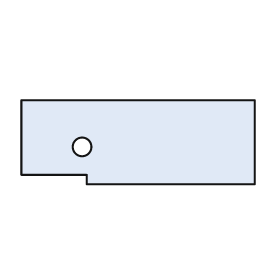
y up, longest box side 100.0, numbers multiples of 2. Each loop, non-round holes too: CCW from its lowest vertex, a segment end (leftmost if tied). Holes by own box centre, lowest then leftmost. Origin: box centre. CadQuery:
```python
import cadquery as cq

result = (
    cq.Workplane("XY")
    .moveTo(-22.0, -18.0)
    .lineTo(50.0, -18.0)
    .lineTo(50.0, 18.0)
    .lineTo(-50.0, 18.0)
    .lineTo(-50.0, -14.0)
    .lineTo(-22.0, -14.0)
    .close()
    .moveTo(-24.0, -2.0)
    .circle(4.0)
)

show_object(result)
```